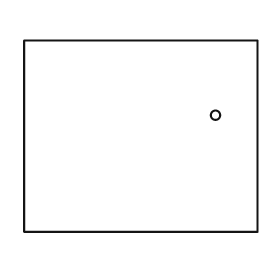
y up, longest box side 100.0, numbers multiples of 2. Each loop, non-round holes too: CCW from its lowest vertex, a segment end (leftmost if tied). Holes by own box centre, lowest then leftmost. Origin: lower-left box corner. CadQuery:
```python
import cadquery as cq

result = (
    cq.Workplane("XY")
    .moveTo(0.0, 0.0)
    .lineTo(100.0, 0.0)
    .lineTo(100.0, 82.0)
    .lineTo(0.0, 82.0)
    .close()
    .moveTo(82.0, 50.0)
    .circle(2.0)
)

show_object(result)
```